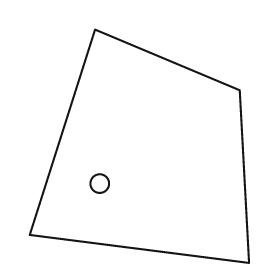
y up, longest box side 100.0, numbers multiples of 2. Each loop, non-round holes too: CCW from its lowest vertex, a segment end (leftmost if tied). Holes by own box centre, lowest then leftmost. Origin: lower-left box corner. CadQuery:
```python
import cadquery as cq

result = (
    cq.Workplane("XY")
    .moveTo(94.0, 0.0)
    .lineTo(90.0, 74.0)
    .lineTo(28.0, 100.0)
    .lineTo(0.0, 12.0)
    .close()
    .moveTo(30.0, 34.0)
    .circle(4.0)
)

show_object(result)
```